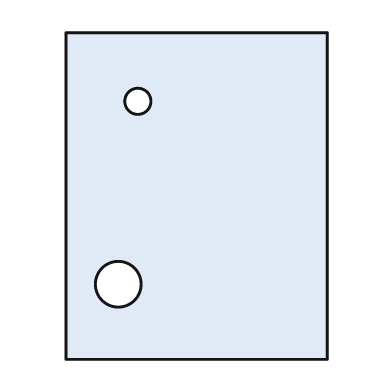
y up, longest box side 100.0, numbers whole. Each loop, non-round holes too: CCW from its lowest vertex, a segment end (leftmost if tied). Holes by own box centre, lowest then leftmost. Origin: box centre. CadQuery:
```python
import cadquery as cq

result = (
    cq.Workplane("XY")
    .moveTo(-40.0, -50.0)
    .lineTo(40.0, -50.0)
    .lineTo(40.0, 50.0)
    .lineTo(-40.0, 50.0)
    .close()
    .moveTo(-24.0, -27.0)
    .circle(7.0)
    .moveTo(-18.0, 29.0)
    .circle(4.0)
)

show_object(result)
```